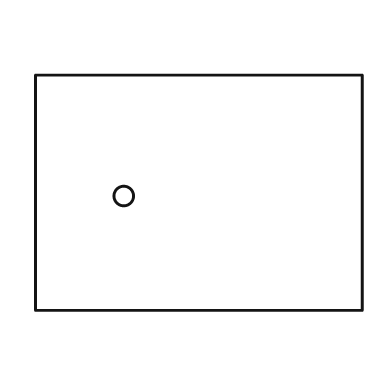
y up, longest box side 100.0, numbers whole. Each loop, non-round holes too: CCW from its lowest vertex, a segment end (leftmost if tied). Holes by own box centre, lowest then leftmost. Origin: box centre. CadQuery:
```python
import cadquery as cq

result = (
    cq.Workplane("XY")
    .moveTo(-50.0, -36.0)
    .lineTo(50.0, -36.0)
    .lineTo(50.0, 36.0)
    .lineTo(-50.0, 36.0)
    .close()
    .moveTo(-23.0, -1.0)
    .circle(3.0)
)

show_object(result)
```